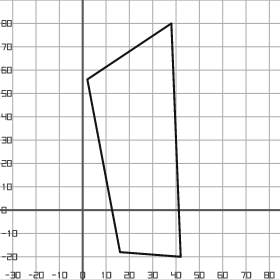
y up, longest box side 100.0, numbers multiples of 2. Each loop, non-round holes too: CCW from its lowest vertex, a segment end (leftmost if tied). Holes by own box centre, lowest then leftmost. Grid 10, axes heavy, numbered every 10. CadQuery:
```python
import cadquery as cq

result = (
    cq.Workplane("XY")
    .moveTo(42.0, -20.0)
    .lineTo(38.0, 80.0)
    .lineTo(2.0, 56.0)
    .lineTo(16.0, -18.0)
    .close()
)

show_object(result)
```